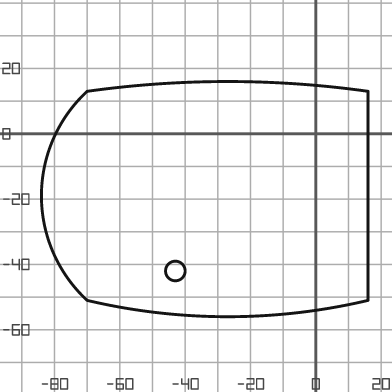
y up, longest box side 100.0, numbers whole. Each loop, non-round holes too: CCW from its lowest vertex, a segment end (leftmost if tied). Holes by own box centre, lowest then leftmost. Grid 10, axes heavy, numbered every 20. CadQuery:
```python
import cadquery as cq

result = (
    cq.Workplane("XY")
    .moveTo(-70.0, -51.0)
    .threePointArc((-27.0, -56.0), (16.0, -51.0))
    .lineTo(16.0, 13.0)
    .threePointArc((-27.0, 16.0), (-70.0, 13.0))
    .threePointArc((-84.0, -19.0), (-70.0, -51.0))
    .close()
    .moveTo(-43.0, -42.0)
    .circle(3.0)
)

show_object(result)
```